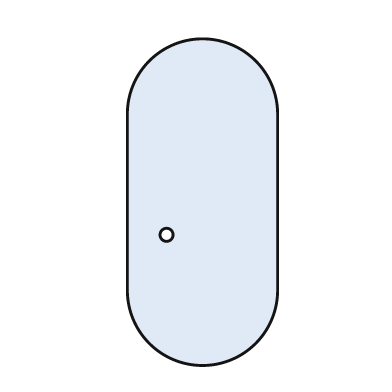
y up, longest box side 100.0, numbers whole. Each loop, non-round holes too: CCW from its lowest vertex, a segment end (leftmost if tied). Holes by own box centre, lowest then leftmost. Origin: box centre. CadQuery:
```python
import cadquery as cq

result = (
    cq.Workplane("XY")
    .moveTo(-23.0, -27.0)
    .threePointArc((0.0, -50.0), (23.0, -27.0))
    .lineTo(23.0, 27.0)
    .threePointArc((0.0, 50.0), (-23.0, 27.0))
    .close()
    .moveTo(-11.0, -10.0)
    .circle(2.0)
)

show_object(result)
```